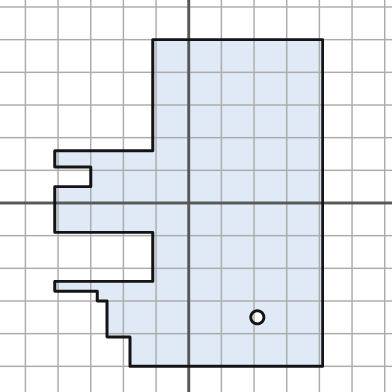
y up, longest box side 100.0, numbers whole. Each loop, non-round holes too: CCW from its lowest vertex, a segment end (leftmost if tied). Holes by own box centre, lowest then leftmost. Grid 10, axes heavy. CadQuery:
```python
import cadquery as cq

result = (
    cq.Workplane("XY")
    .moveTo(-18.0, -50.0)
    .lineTo(41.0, -50.0)
    .lineTo(41.0, 50.0)
    .lineTo(-11.0, 50.0)
    .lineTo(-11.0, 16.0)
    .lineTo(-41.0, 16.0)
    .lineTo(-41.0, 11.0)
    .lineTo(-30.0, 11.0)
    .lineTo(-30.0, 5.0)
    .lineTo(-41.0, 5.0)
    .lineTo(-41.0, -9.0)
    .lineTo(-11.0, -9.0)
    .lineTo(-11.0, -24.0)
    .lineTo(-41.0, -24.0)
    .lineTo(-41.0, -27.0)
    .lineTo(-28.0, -27.0)
    .lineTo(-28.0, -30.0)
    .lineTo(-25.0, -30.0)
    .lineTo(-25.0, -41.0)
    .lineTo(-18.0, -41.0)
    .close()
    .moveTo(21.0, -35.0)
    .circle(2.0)
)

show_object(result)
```